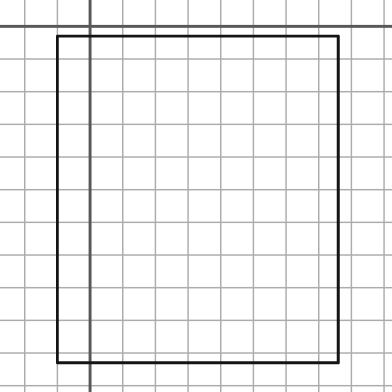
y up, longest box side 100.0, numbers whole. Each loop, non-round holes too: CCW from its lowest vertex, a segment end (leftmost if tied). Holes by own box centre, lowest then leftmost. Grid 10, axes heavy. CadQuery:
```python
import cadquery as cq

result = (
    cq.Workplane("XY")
    .moveTo(-10.0, -103.0)
    .lineTo(76.0, -103.0)
    .lineTo(76.0, -3.0)
    .lineTo(-10.0, -3.0)
    .close()
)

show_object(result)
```